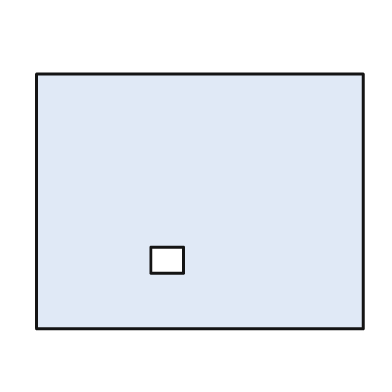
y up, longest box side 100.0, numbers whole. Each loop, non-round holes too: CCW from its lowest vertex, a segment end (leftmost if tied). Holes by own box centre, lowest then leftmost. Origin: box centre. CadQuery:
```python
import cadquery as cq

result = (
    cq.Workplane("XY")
    .moveTo(-50.0, -39.0)
    .lineTo(50.0, -39.0)
    .lineTo(50.0, 39.0)
    .lineTo(-50.0, 39.0)
    .close()
    .moveTo(-15.0, -22.0)
    .lineTo(-5.0, -22.0)
    .lineTo(-5.0, -14.0)
    .lineTo(-15.0, -14.0)
    .close()
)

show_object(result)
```